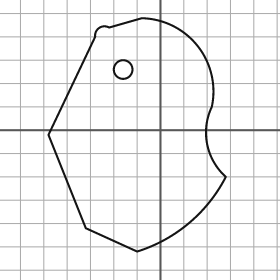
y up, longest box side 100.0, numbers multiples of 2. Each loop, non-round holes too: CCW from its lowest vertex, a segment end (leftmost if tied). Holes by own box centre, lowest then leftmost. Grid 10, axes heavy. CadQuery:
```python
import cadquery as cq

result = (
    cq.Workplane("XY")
    .moveTo(-10.0, -52.0)
    .threePointArc((12.0, -40.0), (28.0, -20.0))
    .threePointArc((20.0, -6.0), (22.0, 10.0))
    .threePointArc((16.0, 36.0), (-8.0, 48.0))
    .lineTo(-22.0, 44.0)
    .threePointArc((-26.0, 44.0), (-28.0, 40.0))
    .lineTo(-48.0, -2.0)
    .lineTo(-32.0, -42.0)
    .close()
    .moveTo(-16.0, 26.0)
    .circle(4.0)
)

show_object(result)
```